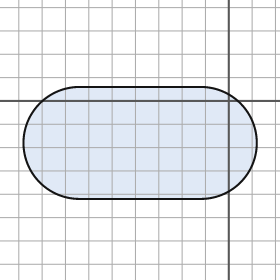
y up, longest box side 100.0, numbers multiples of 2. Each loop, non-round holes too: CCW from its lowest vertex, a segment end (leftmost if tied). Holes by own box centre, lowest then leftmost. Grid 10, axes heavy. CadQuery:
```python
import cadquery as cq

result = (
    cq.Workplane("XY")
    .moveTo(-64.0, -42.0)
    .lineTo(-12.0, -42.0)
    .threePointArc((12.0, -18.0), (-12.0, 6.0))
    .lineTo(-64.0, 6.0)
    .threePointArc((-88.0, -18.0), (-64.0, -42.0))
    .close()
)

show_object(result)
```